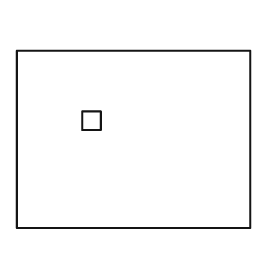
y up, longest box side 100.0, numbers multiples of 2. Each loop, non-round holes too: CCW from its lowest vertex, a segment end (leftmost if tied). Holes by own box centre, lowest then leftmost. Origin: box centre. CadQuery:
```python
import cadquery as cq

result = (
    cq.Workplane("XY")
    .moveTo(-50.0, -38.0)
    .lineTo(50.0, -38.0)
    .lineTo(50.0, 38.0)
    .lineTo(-50.0, 38.0)
    .close()
    .moveTo(-22.0, 4.0)
    .lineTo(-14.0, 4.0)
    .lineTo(-14.0, 12.0)
    .lineTo(-22.0, 12.0)
    .close()
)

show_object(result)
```